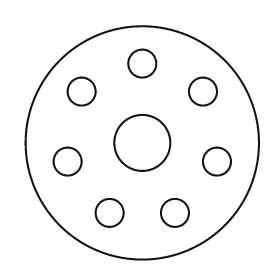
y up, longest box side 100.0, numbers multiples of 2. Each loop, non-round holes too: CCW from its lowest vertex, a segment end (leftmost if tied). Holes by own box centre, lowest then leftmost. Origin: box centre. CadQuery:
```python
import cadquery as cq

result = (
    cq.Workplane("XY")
    .moveTo(0.0, 0.0)
    .circle(50.0)
    .moveTo(-14.0, -30.0)
    .circle(6.0)
    .moveTo(14.0, -30.0)
    .circle(6.0)
    .moveTo(-32.0, -8.0)
    .circle(6.0)
    .moveTo(32.0, -8.0)
    .circle(6.0)
    .moveTo(0.0, 0.0)
    .circle(12.0)
    .moveTo(-26.0, 22.0)
    .circle(6.0)
    .moveTo(26.0, 22.0)
    .circle(6.0)
    .moveTo(0.0, 34.0)
    .circle(6.0)
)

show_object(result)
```